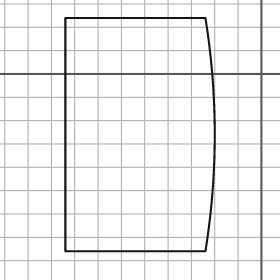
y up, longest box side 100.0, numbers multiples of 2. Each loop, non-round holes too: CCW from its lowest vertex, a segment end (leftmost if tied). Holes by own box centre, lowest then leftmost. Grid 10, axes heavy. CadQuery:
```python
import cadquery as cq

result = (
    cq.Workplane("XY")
    .moveTo(-84.0, -76.0)
    .lineTo(-24.0, -76.0)
    .threePointArc((-20.0, -26.0), (-24.0, 24.0))
    .lineTo(-84.0, 24.0)
    .close()
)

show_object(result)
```